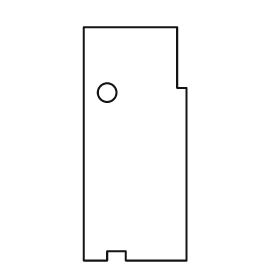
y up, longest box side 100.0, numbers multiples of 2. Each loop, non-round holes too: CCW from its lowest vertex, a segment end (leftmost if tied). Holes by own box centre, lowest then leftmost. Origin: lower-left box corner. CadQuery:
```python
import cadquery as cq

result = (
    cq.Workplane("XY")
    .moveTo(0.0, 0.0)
    .lineTo(10.0, 0.0)
    .lineTo(10.0, 4.0)
    .lineTo(18.0, 4.0)
    .lineTo(18.0, 0.0)
    .lineTo(44.0, 0.0)
    .lineTo(44.0, 74.0)
    .lineTo(40.0, 74.0)
    .lineTo(40.0, 100.0)
    .lineTo(0.0, 100.0)
    .close()
    .moveTo(10.0, 72.0)
    .circle(4.0)
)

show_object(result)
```